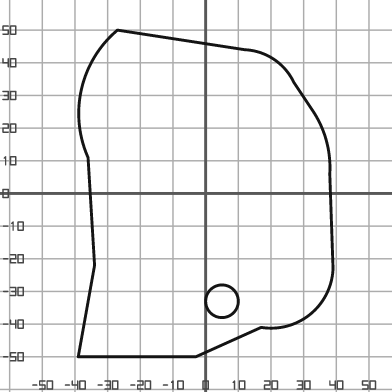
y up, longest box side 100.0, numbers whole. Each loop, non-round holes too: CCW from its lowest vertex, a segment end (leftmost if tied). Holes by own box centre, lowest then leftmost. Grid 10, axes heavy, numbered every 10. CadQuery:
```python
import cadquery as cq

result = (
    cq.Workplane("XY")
    .moveTo(-39.0, -50.0)
    .lineTo(-3.0, -50.0)
    .lineTo(17.0, -41.0)
    .threePointArc((32.0, -37.0), (39.0, -23.0))
    .lineTo(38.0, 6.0)
    .threePointArc((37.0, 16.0), (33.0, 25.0))
    .lineTo(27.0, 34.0)
    .threePointArc((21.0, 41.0), (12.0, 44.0))
    .lineTo(-27.0, 50.0)
    .threePointArc((-38.0, 32.0), (-36.0, 11.0))
    .lineTo(-34.0, -22.0)
    .close()
    .moveTo(5.0, -33.0)
    .circle(5.0)
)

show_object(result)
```